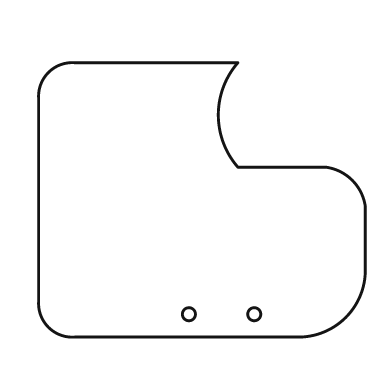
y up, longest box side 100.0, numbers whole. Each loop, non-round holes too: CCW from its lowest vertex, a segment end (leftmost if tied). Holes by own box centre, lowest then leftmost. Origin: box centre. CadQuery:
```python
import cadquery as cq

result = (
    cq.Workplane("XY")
    .moveTo(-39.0, -42.0)
    .lineTo(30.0, -42.0)
    .threePointArc((44.0, -36.0), (50.0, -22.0))
    .lineTo(50.0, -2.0)
    .threePointArc((46.0, 6.0), (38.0, 10.0))
    .lineTo(11.0, 10.0)
    .threePointArc((5.0, 26.0), (11.0, 42.0))
    .lineTo(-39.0, 42.0)
    .threePointArc((-47.0, 39.0), (-50.0, 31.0))
    .lineTo(-50.0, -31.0)
    .threePointArc((-47.0, -39.0), (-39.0, -42.0))
    .close()
    .moveTo(-4.0, -35.0)
    .circle(2.0)
    .moveTo(16.0, -35.0)
    .circle(2.0)
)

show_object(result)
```